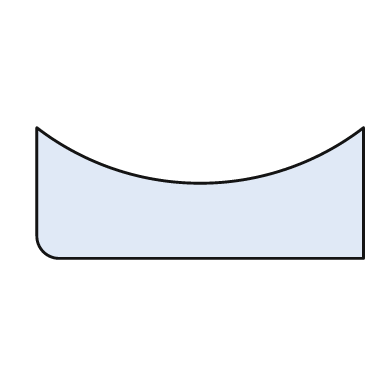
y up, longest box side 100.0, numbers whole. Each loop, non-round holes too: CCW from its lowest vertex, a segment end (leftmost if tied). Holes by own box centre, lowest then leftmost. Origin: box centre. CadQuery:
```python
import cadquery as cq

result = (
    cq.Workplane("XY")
    .moveTo(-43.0, -20.0)
    .lineTo(50.0, -20.0)
    .lineTo(50.0, 20.0)
    .threePointArc((0.0, 3.0), (-50.0, 20.0))
    .lineTo(-50.0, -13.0)
    .threePointArc((-48.0, -18.0), (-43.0, -20.0))
    .close()
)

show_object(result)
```